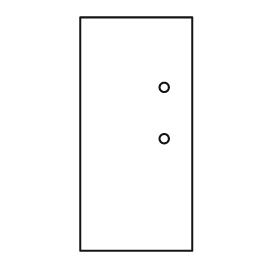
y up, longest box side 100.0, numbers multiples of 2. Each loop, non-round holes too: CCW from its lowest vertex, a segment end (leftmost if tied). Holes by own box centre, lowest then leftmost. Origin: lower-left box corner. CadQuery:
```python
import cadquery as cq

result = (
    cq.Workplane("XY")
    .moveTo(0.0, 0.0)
    .lineTo(48.0, 0.0)
    .lineTo(48.0, 100.0)
    .lineTo(0.0, 100.0)
    .close()
    .moveTo(36.0, 48.0)
    .circle(2.0)
    .moveTo(36.0, 70.0)
    .circle(2.0)
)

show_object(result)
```